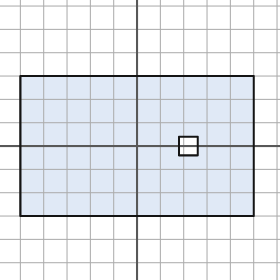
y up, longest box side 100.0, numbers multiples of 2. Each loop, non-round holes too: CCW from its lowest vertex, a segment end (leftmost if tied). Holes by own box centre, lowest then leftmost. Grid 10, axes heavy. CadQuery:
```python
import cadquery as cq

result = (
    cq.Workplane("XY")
    .moveTo(-50.0, -30.0)
    .lineTo(50.0, -30.0)
    .lineTo(50.0, 30.0)
    .lineTo(-50.0, 30.0)
    .close()
    .moveTo(18.0, -4.0)
    .lineTo(26.0, -4.0)
    .lineTo(26.0, 4.0)
    .lineTo(18.0, 4.0)
    .close()
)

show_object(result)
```